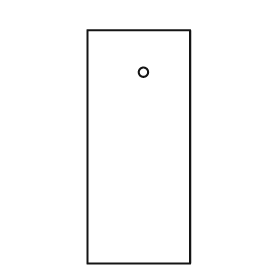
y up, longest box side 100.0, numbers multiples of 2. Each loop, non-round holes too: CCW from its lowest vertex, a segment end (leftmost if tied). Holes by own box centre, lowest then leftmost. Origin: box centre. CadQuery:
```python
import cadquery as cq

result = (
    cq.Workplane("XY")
    .moveTo(-22.0, -50.0)
    .lineTo(22.0, -50.0)
    .lineTo(22.0, 50.0)
    .lineTo(-22.0, 50.0)
    .close()
    .moveTo(2.0, 32.0)
    .circle(2.0)
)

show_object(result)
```